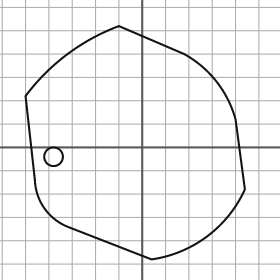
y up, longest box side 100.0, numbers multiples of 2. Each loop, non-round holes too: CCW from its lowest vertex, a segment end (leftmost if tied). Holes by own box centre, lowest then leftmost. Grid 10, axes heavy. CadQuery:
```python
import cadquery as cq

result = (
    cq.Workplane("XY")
    .moveTo(4.0, -48.0)
    .threePointArc((28.0, -38.0), (44.0, -18.0))
    .lineTo(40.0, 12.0)
    .threePointArc((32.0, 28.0), (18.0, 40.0))
    .lineTo(-10.0, 52.0)
    .threePointArc((-32.0, 40.0), (-50.0, 22.0))
    .lineTo(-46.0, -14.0)
    .threePointArc((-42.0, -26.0), (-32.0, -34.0))
    .close()
    .moveTo(-38.0, -4.0)
    .circle(4.0)
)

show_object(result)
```